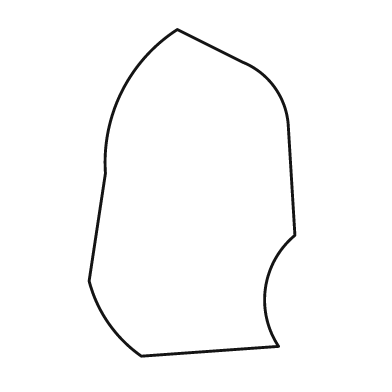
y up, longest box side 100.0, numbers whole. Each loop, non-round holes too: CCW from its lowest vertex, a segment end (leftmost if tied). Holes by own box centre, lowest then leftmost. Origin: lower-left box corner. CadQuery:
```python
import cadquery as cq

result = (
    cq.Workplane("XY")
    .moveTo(16.0, 0.0)
    .lineTo(58.0, 3.0)
    .threePointArc((54.0, 21.0), (63.0, 37.0))
    .lineTo(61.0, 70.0)
    .threePointArc((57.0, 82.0), (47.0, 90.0))
    .lineTo(27.0, 100.0)
    .threePointArc((10.0, 81.0), (5.0, 56.0))
    .lineTo(0.0, 23.0)
    .threePointArc((6.0, 10.0), (16.0, 0.0))
    .close()
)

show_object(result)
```